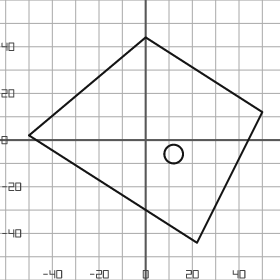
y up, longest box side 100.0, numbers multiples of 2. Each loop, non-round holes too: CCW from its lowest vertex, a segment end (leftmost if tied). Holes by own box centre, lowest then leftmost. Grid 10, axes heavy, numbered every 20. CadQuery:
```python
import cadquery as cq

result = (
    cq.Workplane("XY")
    .moveTo(22.0, -44.0)
    .lineTo(50.0, 12.0)
    .lineTo(0.0, 44.0)
    .lineTo(-50.0, 2.0)
    .close()
    .moveTo(12.0, -6.0)
    .circle(4.0)
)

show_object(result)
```